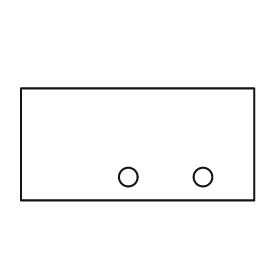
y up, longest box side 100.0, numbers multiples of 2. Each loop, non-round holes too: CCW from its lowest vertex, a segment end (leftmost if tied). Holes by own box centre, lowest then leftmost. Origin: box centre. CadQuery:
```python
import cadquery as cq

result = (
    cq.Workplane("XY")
    .moveTo(-50.0, -24.0)
    .lineTo(50.0, -24.0)
    .lineTo(50.0, 24.0)
    .lineTo(-50.0, 24.0)
    .close()
    .moveTo(-4.0, -14.0)
    .circle(4.0)
    .moveTo(28.0, -14.0)
    .circle(4.0)
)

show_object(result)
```